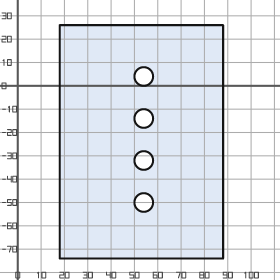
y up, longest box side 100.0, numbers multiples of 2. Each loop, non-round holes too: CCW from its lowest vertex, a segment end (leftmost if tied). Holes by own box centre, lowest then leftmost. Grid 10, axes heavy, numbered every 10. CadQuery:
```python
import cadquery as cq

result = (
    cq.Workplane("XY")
    .moveTo(18.0, -74.0)
    .lineTo(88.0, -74.0)
    .lineTo(88.0, 26.0)
    .lineTo(18.0, 26.0)
    .close()
    .moveTo(54.0, -50.0)
    .circle(4.0)
    .moveTo(54.0, -32.0)
    .circle(4.0)
    .moveTo(54.0, -14.0)
    .circle(4.0)
    .moveTo(54.0, 4.0)
    .circle(4.0)
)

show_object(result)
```